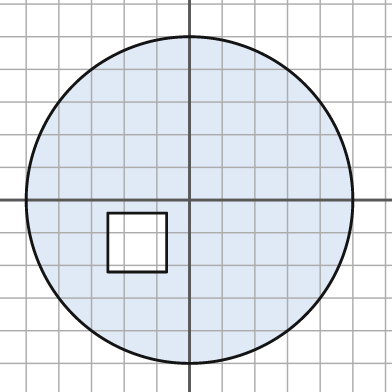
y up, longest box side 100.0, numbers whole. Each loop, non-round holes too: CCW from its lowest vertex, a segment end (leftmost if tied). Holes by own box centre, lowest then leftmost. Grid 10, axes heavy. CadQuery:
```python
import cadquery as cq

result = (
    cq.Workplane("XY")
    .moveTo(0.0, 0.0)
    .circle(50.0)
    .moveTo(-25.0, -22.0)
    .lineTo(-7.0, -22.0)
    .lineTo(-7.0, -4.0)
    .lineTo(-25.0, -4.0)
    .close()
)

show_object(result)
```